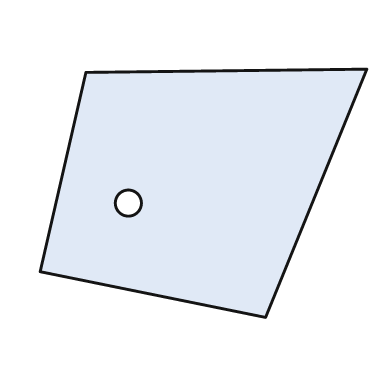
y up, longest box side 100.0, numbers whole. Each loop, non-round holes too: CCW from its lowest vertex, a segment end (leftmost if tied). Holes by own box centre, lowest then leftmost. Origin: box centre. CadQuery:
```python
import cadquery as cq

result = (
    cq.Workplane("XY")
    .moveTo(19.0, -38.0)
    .lineTo(50.0, 38.0)
    .lineTo(-36.0, 37.0)
    .lineTo(-50.0, -24.0)
    .close()
    .moveTo(-23.0, -3.0)
    .circle(4.0)
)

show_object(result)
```